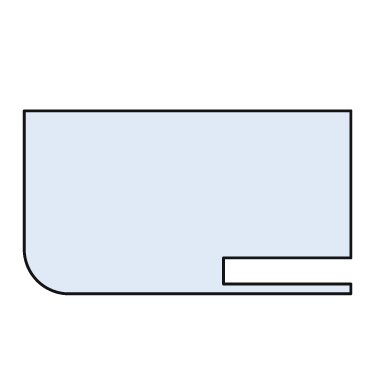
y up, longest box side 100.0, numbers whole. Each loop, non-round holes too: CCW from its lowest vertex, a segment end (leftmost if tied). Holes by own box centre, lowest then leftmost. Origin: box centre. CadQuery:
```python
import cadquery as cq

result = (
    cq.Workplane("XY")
    .moveTo(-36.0, -28.0)
    .lineTo(50.0, -28.0)
    .lineTo(50.0, -25.0)
    .lineTo(11.0, -25.0)
    .lineTo(11.0, -17.0)
    .lineTo(50.0, -17.0)
    .lineTo(50.0, 28.0)
    .lineTo(-50.0, 28.0)
    .lineTo(-50.0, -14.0)
    .threePointArc((-46.0, -24.0), (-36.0, -28.0))
    .close()
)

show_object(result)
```